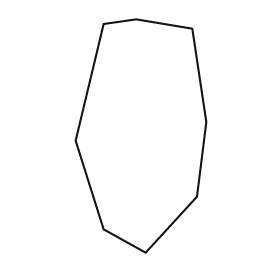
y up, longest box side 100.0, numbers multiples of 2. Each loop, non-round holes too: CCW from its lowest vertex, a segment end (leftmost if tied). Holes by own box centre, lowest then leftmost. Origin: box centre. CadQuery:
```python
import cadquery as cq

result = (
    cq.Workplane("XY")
    .moveTo(2.0, -50.0)
    .lineTo(24.0, -26.0)
    .lineTo(28.0, 6.0)
    .lineTo(22.0, 46.0)
    .lineTo(-2.0, 50.0)
    .lineTo(-16.0, 48.0)
    .lineTo(-28.0, -2.0)
    .lineTo(-16.0, -40.0)
    .close()
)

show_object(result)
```